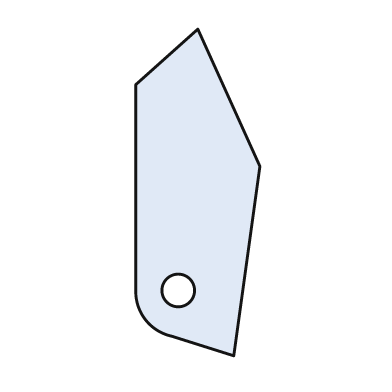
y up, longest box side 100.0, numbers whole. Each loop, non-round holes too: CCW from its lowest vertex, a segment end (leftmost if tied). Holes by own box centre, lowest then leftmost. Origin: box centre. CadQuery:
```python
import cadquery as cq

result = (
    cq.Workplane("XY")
    .moveTo(11.0, -50.0)
    .lineTo(19.0, 8.0)
    .lineTo(0.0, 50.0)
    .lineTo(-19.0, 33.0)
    .lineTo(-19.0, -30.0)
    .threePointArc((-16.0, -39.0), (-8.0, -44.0))
    .close()
    .moveTo(-6.0, -30.0)
    .circle(5.0)
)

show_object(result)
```